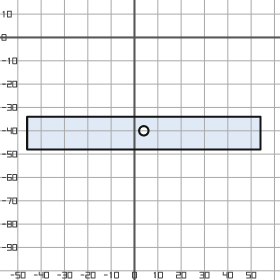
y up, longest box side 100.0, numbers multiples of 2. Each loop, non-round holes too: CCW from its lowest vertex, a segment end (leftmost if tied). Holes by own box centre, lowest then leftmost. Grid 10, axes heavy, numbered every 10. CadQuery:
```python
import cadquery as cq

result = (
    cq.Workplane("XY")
    .moveTo(-46.0, -48.0)
    .lineTo(54.0, -48.0)
    .lineTo(54.0, -34.0)
    .lineTo(-46.0, -34.0)
    .close()
    .moveTo(4.0, -40.0)
    .circle(2.0)
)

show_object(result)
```